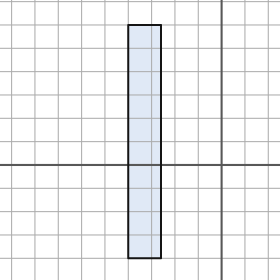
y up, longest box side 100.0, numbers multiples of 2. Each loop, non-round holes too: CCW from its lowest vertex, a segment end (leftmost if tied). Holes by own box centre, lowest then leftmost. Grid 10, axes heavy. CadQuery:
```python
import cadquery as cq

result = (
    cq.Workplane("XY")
    .moveTo(-40.0, -40.0)
    .lineTo(-26.0, -40.0)
    .lineTo(-26.0, 60.0)
    .lineTo(-40.0, 60.0)
    .close()
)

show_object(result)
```